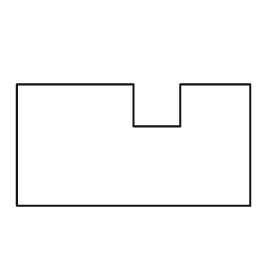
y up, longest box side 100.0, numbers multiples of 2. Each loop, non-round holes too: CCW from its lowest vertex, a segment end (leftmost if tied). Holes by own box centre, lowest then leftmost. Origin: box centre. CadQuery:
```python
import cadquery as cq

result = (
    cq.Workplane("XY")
    .moveTo(-50.0, -26.0)
    .lineTo(50.0, -26.0)
    .lineTo(50.0, 26.0)
    .lineTo(20.0, 26.0)
    .lineTo(20.0, 8.0)
    .lineTo(0.0, 8.0)
    .lineTo(0.0, 26.0)
    .lineTo(-50.0, 26.0)
    .close()
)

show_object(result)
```